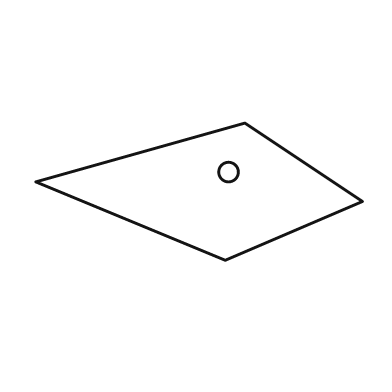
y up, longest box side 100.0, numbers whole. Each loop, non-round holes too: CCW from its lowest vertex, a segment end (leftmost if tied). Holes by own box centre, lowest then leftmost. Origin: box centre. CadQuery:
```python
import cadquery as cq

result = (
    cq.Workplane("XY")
    .moveTo(8.0, -21.0)
    .lineTo(50.0, -3.0)
    .lineTo(14.0, 21.0)
    .lineTo(-50.0, 3.0)
    .close()
    .moveTo(9.0, 6.0)
    .circle(3.0)
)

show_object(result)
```